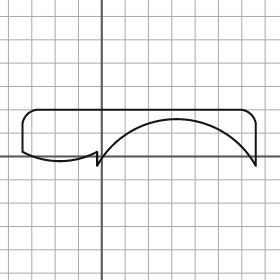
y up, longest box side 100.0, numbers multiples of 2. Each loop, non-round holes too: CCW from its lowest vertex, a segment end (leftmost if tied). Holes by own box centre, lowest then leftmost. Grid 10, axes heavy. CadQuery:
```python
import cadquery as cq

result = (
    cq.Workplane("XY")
    .moveTo(-2.0, -4.0)
    .threePointArc((32.0, 16.0), (66.0, -4.0))
    .lineTo(66.0, 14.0)
    .threePointArc((64.0, 18.0), (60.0, 20.0))
    .lineTo(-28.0, 20.0)
    .threePointArc((-32.0, 18.0), (-34.0, 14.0))
    .lineTo(-34.0, 2.0)
    .threePointArc((-18.0, -2.0), (-2.0, 2.0))
    .close()
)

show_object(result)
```